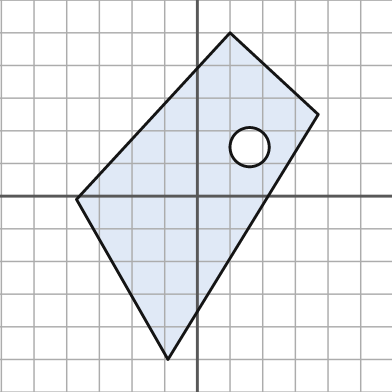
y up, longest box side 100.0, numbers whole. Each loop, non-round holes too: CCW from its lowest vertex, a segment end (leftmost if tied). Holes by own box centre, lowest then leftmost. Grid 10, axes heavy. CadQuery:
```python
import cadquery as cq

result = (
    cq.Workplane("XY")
    .moveTo(-9.0, -50.0)
    .lineTo(37.0, 25.0)
    .lineTo(10.0, 50.0)
    .lineTo(-37.0, -1.0)
    .close()
    .moveTo(16.0, 15.0)
    .circle(6.0)
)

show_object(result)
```